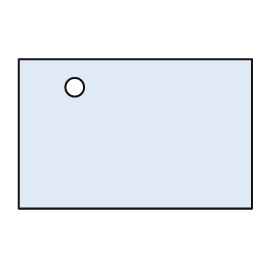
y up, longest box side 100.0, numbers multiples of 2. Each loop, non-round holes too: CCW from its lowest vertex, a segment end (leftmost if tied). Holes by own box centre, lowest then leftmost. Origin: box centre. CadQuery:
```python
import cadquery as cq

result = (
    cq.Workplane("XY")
    .moveTo(-50.0, -32.0)
    .lineTo(50.0, -32.0)
    .lineTo(50.0, 32.0)
    .lineTo(-50.0, 32.0)
    .close()
    .moveTo(-26.0, 20.0)
    .circle(4.0)
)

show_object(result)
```